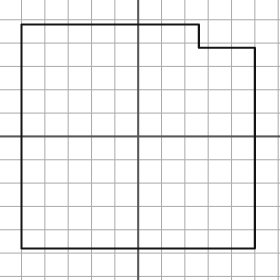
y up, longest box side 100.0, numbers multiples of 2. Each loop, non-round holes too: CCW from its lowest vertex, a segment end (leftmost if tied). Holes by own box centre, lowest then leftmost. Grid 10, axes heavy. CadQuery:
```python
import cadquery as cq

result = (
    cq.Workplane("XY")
    .moveTo(-50.0, -48.0)
    .lineTo(50.0, -48.0)
    .lineTo(50.0, 38.0)
    .lineTo(26.0, 38.0)
    .lineTo(26.0, 48.0)
    .lineTo(-50.0, 48.0)
    .close()
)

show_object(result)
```